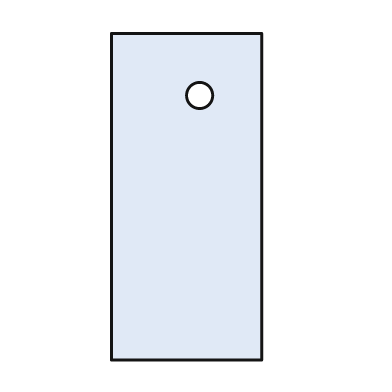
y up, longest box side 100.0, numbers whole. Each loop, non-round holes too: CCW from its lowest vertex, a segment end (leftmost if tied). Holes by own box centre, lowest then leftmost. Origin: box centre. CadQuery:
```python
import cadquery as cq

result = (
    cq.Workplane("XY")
    .moveTo(-23.0, -50.0)
    .lineTo(23.0, -50.0)
    .lineTo(23.0, 50.0)
    .lineTo(-23.0, 50.0)
    .close()
    .moveTo(4.0, 31.0)
    .circle(4.0)
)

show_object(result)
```